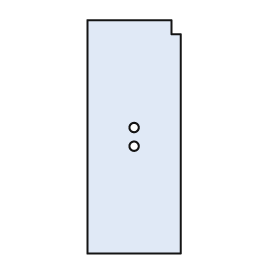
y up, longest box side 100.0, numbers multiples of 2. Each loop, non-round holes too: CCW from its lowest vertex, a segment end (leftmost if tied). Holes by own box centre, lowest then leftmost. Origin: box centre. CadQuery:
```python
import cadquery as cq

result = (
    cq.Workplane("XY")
    .moveTo(-20.0, -50.0)
    .lineTo(20.0, -50.0)
    .lineTo(20.0, 44.0)
    .lineTo(16.0, 44.0)
    .lineTo(16.0, 50.0)
    .lineTo(-20.0, 50.0)
    .close()
    .moveTo(0.0, -4.0)
    .circle(2.0)
    .moveTo(0.0, 4.0)
    .circle(2.0)
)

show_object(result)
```